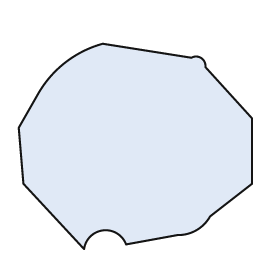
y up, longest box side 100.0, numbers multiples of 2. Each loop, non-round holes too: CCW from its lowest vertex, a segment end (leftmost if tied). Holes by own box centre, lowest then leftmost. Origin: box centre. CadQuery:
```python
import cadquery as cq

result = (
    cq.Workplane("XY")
    .moveTo(-22.0, -44.0)
    .threePointArc((-14.0, -36.0), (-4.0, -42.0))
    .lineTo(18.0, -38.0)
    .threePointArc((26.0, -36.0), (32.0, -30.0))
    .lineTo(50.0, -16.0)
    .lineTo(50.0, 12.0)
    .lineTo(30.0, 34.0)
    .threePointArc((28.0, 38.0), (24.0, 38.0))
    .lineTo(-14.0, 44.0)
    .threePointArc((-30.0, 36.0), (-42.0, 22.0))
    .lineTo(-50.0, 8.0)
    .lineTo(-48.0, -16.0)
    .close()
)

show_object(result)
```